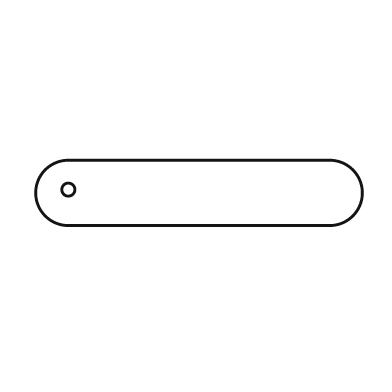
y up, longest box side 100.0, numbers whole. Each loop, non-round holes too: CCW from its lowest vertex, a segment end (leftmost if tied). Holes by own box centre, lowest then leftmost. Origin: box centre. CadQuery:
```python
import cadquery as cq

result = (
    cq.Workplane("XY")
    .moveTo(-40.0, -10.0)
    .lineTo(40.0, -10.0)
    .threePointArc((50.0, 0.0), (40.0, 10.0))
    .lineTo(-40.0, 10.0)
    .threePointArc((-50.0, 0.0), (-40.0, -10.0))
    .close()
    .moveTo(-40.0, 1.0)
    .circle(2.0)
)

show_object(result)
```